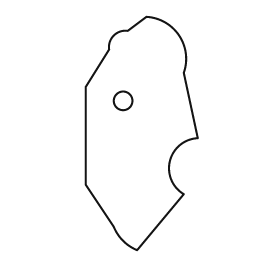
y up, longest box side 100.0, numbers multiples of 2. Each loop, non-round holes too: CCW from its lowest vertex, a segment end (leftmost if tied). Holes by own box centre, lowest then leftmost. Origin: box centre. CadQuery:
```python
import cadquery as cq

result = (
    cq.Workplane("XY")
    .moveTo(-2.0, -50.0)
    .lineTo(18.0, -26.0)
    .threePointArc((12.0, -12.0), (24.0, -2.0))
    .lineTo(18.0, 26.0)
    .threePointArc((16.0, 42.0), (2.0, 50.0))
    .lineTo(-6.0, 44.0)
    .threePointArc((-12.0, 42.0), (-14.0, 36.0))
    .lineTo(-24.0, 20.0)
    .lineTo(-24.0, -22.0)
    .lineTo(-12.0, -40.0)
    .threePointArc((-8.0, -46.0), (-2.0, -50.0))
    .close()
    .moveTo(-8.0, 14.0)
    .circle(4.0)
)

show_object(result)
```